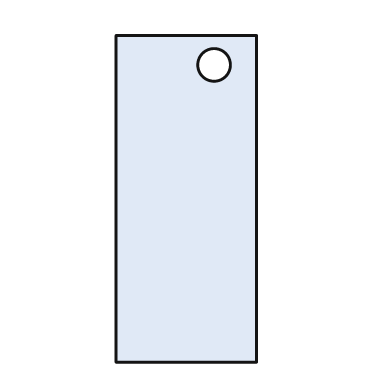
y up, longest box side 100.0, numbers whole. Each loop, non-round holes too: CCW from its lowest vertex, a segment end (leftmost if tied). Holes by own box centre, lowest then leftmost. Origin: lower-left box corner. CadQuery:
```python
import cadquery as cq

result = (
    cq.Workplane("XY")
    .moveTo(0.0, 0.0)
    .lineTo(43.0, 0.0)
    .lineTo(43.0, 100.0)
    .lineTo(0.0, 100.0)
    .close()
    .moveTo(30.0, 91.0)
    .circle(5.0)
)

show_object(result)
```